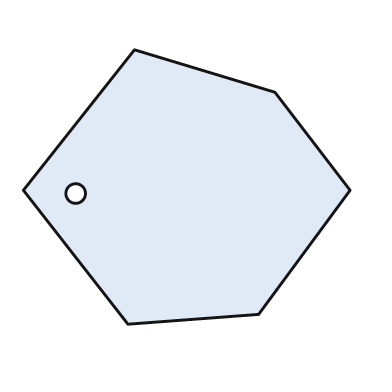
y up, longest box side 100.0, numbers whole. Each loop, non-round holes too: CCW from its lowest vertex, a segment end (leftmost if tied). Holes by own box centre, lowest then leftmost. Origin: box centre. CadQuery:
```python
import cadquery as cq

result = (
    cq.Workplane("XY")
    .moveTo(-18.0, -42.0)
    .lineTo(22.0, -39.0)
    .lineTo(50.0, -1.0)
    .lineTo(27.0, 29.0)
    .lineTo(-16.0, 42.0)
    .lineTo(-50.0, -1.0)
    .close()
    .moveTo(-34.0, -2.0)
    .circle(3.0)
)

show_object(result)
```